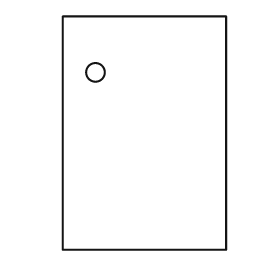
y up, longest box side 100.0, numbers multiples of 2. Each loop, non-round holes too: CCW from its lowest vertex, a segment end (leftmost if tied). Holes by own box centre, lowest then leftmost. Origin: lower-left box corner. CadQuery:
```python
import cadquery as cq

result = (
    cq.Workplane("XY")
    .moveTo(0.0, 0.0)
    .lineTo(70.0, 0.0)
    .lineTo(70.0, 100.0)
    .lineTo(0.0, 100.0)
    .close()
    .moveTo(14.0, 76.0)
    .circle(4.0)
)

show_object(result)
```